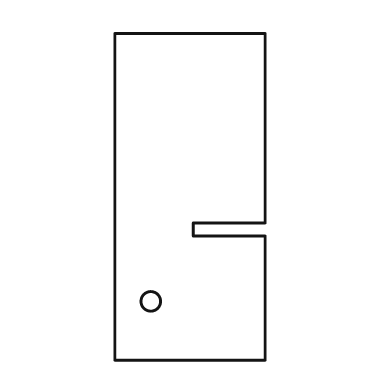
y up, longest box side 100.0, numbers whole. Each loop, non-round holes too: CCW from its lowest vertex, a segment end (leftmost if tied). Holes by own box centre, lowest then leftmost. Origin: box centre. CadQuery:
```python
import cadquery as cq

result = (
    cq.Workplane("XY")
    .moveTo(-23.0, -50.0)
    .lineTo(23.0, -50.0)
    .lineTo(23.0, -12.0)
    .lineTo(1.0, -12.0)
    .lineTo(1.0, -8.0)
    .lineTo(23.0, -8.0)
    .lineTo(23.0, 50.0)
    .lineTo(-23.0, 50.0)
    .close()
    .moveTo(-12.0, -32.0)
    .circle(3.0)
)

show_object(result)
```